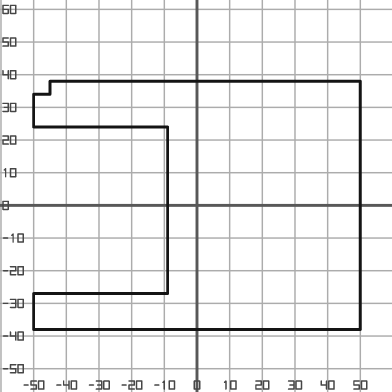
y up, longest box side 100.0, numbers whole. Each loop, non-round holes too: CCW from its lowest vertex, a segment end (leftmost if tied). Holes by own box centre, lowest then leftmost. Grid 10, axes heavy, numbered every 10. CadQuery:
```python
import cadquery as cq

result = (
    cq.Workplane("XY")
    .moveTo(-50.0, -38.0)
    .lineTo(50.0, -38.0)
    .lineTo(50.0, 38.0)
    .lineTo(-45.0, 38.0)
    .lineTo(-45.0, 34.0)
    .lineTo(-50.0, 34.0)
    .lineTo(-50.0, 24.0)
    .lineTo(-9.0, 24.0)
    .lineTo(-9.0, -27.0)
    .lineTo(-50.0, -27.0)
    .close()
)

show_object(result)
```